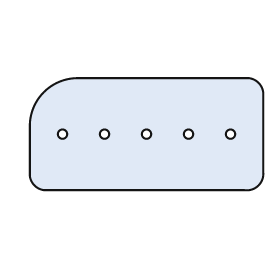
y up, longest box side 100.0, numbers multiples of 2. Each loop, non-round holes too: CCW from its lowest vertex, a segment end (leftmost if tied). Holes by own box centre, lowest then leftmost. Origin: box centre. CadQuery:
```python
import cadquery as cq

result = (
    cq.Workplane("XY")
    .moveTo(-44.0, -24.0)
    .lineTo(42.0, -24.0)
    .threePointArc((48.0, -22.0), (50.0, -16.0))
    .lineTo(50.0, 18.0)
    .threePointArc((48.0, 22.0), (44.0, 24.0))
    .lineTo(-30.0, 24.0)
    .threePointArc((-44.0, 18.0), (-50.0, 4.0))
    .lineTo(-50.0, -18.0)
    .threePointArc((-48.0, -22.0), (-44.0, -24.0))
    .close()
    .moveTo(-36.0, 0.0)
    .circle(2.0)
    .moveTo(-18.0, 0.0)
    .circle(2.0)
    .moveTo(0.0, 0.0)
    .circle(2.0)
    .moveTo(18.0, 0.0)
    .circle(2.0)
    .moveTo(36.0, 0.0)
    .circle(2.0)
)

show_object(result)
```